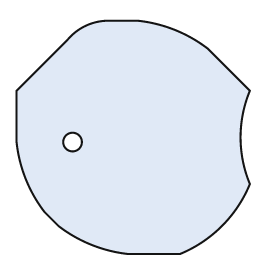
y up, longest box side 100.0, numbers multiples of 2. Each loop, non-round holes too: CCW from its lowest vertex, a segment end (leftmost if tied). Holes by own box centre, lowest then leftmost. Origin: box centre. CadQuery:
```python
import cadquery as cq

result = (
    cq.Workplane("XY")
    .moveTo(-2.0, -50.0)
    .lineTo(20.0, -50.0)
    .threePointArc((38.0, -38.0), (50.0, -20.0))
    .threePointArc((46.0, 0.0), (50.0, 20.0))
    .lineTo(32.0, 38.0)
    .threePointArc((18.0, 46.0), (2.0, 50.0))
    .lineTo(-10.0, 50.0)
    .threePointArc((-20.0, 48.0), (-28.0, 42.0))
    .lineTo(-50.0, 20.0)
    .lineTo(-50.0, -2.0)
    .threePointArc((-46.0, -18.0), (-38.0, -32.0))
    .lineTo(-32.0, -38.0)
    .threePointArc((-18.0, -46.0), (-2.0, -50.0))
    .close()
    .moveTo(-26.0, -2.0)
    .circle(4.0)
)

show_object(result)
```